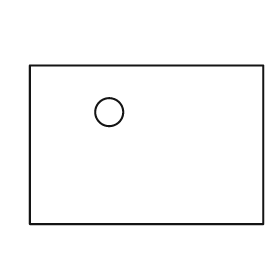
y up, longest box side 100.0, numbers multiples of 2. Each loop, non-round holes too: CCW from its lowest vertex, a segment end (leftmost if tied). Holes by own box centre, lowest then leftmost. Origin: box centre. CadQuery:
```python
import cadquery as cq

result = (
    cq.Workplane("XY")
    .moveTo(-50.0, -34.0)
    .lineTo(50.0, -34.0)
    .lineTo(50.0, 34.0)
    .lineTo(-50.0, 34.0)
    .close()
    .moveTo(-16.0, 14.0)
    .circle(6.0)
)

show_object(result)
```